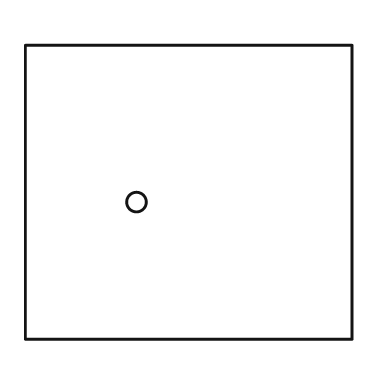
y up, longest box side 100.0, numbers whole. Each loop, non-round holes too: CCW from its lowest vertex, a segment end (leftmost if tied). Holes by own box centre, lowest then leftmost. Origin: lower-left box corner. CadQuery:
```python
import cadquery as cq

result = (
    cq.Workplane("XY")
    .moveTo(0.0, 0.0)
    .lineTo(100.0, 0.0)
    .lineTo(100.0, 90.0)
    .lineTo(0.0, 90.0)
    .close()
    .moveTo(34.0, 42.0)
    .circle(3.0)
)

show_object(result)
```